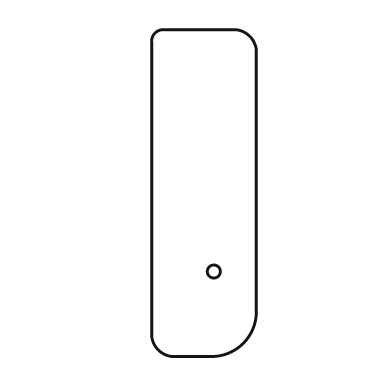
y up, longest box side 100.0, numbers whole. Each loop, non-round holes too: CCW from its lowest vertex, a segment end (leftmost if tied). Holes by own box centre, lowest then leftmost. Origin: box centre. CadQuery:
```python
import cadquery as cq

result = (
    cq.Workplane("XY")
    .moveTo(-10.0, -50.0)
    .lineTo(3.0, -50.0)
    .threePointArc((12.0, -46.0), (16.0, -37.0))
    .lineTo(16.0, 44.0)
    .threePointArc((14.0, 48.0), (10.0, 50.0))
    .lineTo(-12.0, 50.0)
    .threePointArc((-15.0, 49.0), (-16.0, 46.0))
    .lineTo(-16.0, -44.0)
    .threePointArc((-14.0, -48.0), (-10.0, -50.0))
    .close()
    .moveTo(3.0, -24.0)
    .circle(2.0)
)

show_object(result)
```